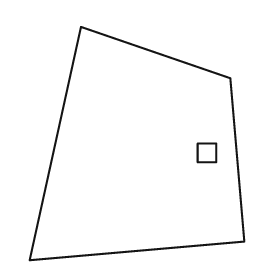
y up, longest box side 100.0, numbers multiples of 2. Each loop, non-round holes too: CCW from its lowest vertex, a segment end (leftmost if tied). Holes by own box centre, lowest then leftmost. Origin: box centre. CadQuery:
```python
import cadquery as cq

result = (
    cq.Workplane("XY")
    .moveTo(-46.0, -50.0)
    .lineTo(46.0, -42.0)
    .lineTo(40.0, 28.0)
    .lineTo(-24.0, 50.0)
    .close()
    .moveTo(26.0, -8.0)
    .lineTo(34.0, -8.0)
    .lineTo(34.0, 0.0)
    .lineTo(26.0, 0.0)
    .close()
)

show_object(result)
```